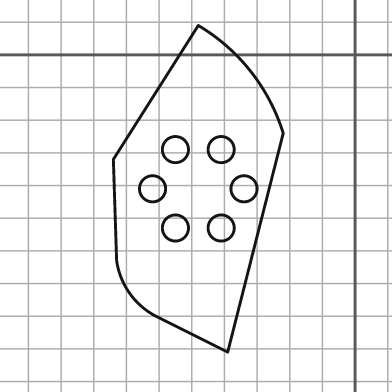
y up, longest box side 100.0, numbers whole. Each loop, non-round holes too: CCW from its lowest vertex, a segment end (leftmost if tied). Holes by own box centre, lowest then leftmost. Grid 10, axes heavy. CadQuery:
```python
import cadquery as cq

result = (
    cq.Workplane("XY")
    .moveTo(-39.0, -91.0)
    .lineTo(-22.0, -24.0)
    .threePointArc((-32.0, -5.0), (-48.0, 9.0))
    .lineTo(-74.0, -32.0)
    .lineTo(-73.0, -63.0)
    .threePointArc((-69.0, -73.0), (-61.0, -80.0))
    .close()
    .moveTo(-55.0, -53.0)
    .circle(4.0)
    .moveTo(-41.0, -53.0)
    .circle(4.0)
    .moveTo(-62.0, -41.0)
    .circle(4.0)
    .moveTo(-34.0, -41.0)
    .circle(4.0)
    .moveTo(-55.0, -29.0)
    .circle(4.0)
    .moveTo(-41.0, -29.0)
    .circle(4.0)
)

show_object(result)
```